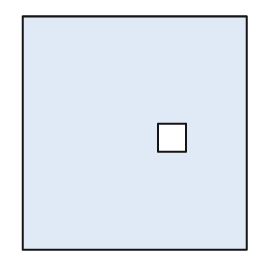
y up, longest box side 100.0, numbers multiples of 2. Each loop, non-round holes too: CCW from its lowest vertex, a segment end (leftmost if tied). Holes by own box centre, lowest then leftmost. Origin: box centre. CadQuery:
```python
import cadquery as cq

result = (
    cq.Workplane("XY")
    .moveTo(-48.0, -50.0)
    .lineTo(48.0, -50.0)
    .lineTo(48.0, 50.0)
    .lineTo(-48.0, 50.0)
    .close()
    .moveTo(10.0, -8.0)
    .lineTo(22.0, -8.0)
    .lineTo(22.0, 4.0)
    .lineTo(10.0, 4.0)
    .close()
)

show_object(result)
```